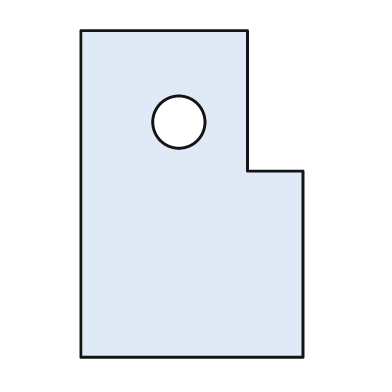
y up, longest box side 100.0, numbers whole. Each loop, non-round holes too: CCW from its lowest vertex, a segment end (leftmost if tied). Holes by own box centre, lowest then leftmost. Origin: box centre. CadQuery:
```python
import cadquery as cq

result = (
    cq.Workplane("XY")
    .moveTo(-34.0, -50.0)
    .lineTo(34.0, -50.0)
    .lineTo(34.0, 7.0)
    .lineTo(17.0, 7.0)
    .lineTo(17.0, 50.0)
    .lineTo(-34.0, 50.0)
    .close()
    .moveTo(-4.0, 22.0)
    .circle(8.0)
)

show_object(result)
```